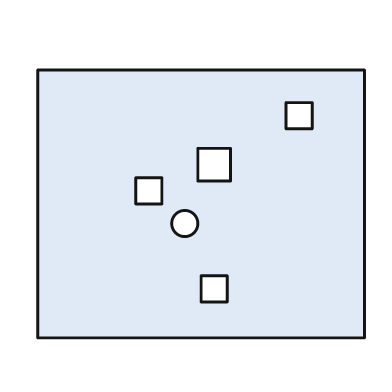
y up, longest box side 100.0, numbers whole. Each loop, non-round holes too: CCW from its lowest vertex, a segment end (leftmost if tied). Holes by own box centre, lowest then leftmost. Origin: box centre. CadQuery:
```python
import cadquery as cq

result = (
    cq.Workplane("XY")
    .moveTo(-50.0, -41.0)
    .lineTo(50.0, -41.0)
    .lineTo(50.0, 41.0)
    .lineTo(-50.0, 41.0)
    .close()
    .moveTo(0.0, -30.0)
    .lineTo(8.0, -30.0)
    .lineTo(8.0, -22.0)
    .lineTo(0.0, -22.0)
    .close()
    .moveTo(-5.0, -6.0)
    .circle(4.0)
    .moveTo(-20.0, 0.0)
    .lineTo(-12.0, 0.0)
    .lineTo(-12.0, 8.0)
    .lineTo(-20.0, 8.0)
    .close()
    .moveTo(-1.0, 7.0)
    .lineTo(9.0, 7.0)
    .lineTo(9.0, 17.0)
    .lineTo(-1.0, 17.0)
    .close()
    .moveTo(26.0, 23.0)
    .lineTo(34.0, 23.0)
    .lineTo(34.0, 31.0)
    .lineTo(26.0, 31.0)
    .close()
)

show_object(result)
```